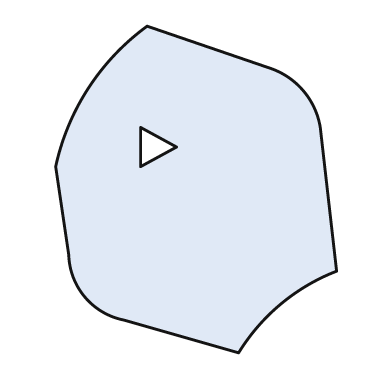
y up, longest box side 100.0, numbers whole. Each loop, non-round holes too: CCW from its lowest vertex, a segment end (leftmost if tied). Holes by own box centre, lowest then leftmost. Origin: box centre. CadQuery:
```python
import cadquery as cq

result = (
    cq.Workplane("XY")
    .moveTo(13.0, -50.0)
    .threePointArc((26.0, -35.0), (43.0, -25.0))
    .lineTo(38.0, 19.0)
    .threePointArc((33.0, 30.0), (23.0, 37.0))
    .lineTo(-15.0, 50.0)
    .threePointArc((-33.0, 31.0), (-43.0, 7.0))
    .lineTo(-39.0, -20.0)
    .threePointArc((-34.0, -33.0), (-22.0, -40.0))
    .close()
    .moveTo(-17.0, 7.0)
    .lineTo(-6.0, 13.0)
    .lineTo(-17.0, 19.0)
    .close()
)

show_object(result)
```